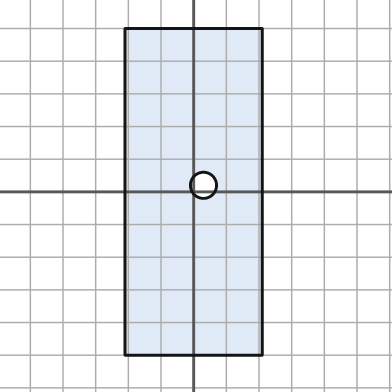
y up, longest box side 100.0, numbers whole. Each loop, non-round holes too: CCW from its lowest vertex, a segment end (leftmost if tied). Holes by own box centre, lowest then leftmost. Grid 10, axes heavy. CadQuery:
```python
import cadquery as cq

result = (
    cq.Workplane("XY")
    .moveTo(-21.0, -50.0)
    .lineTo(21.0, -50.0)
    .lineTo(21.0, 50.0)
    .lineTo(-21.0, 50.0)
    .close()
    .moveTo(3.0, 2.0)
    .circle(4.0)
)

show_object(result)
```